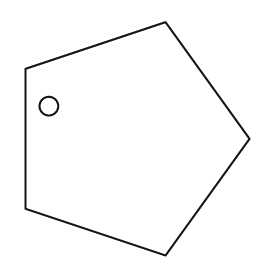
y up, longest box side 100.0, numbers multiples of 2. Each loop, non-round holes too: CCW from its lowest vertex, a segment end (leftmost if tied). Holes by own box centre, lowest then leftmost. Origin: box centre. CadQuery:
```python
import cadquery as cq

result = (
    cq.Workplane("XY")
    .moveTo(12.0, -50.0)
    .lineTo(48.0, 0.0)
    .lineTo(12.0, 50.0)
    .lineTo(-48.0, 30.0)
    .lineTo(-48.0, -30.0)
    .close()
    .moveTo(-38.0, 14.0)
    .circle(4.0)
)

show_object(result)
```